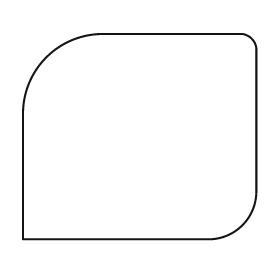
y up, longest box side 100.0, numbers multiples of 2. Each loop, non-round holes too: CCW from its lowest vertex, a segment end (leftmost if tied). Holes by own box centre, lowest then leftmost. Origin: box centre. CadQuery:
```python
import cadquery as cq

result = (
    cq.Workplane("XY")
    .moveTo(-50.0, -44.0)
    .lineTo(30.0, -44.0)
    .threePointArc((44.0, -38.0), (50.0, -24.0))
    .lineTo(50.0, 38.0)
    .threePointArc((48.0, 42.0), (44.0, 44.0))
    .lineTo(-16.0, 44.0)
    .threePointArc((-40.0, 34.0), (-50.0, 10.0))
    .close()
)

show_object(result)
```